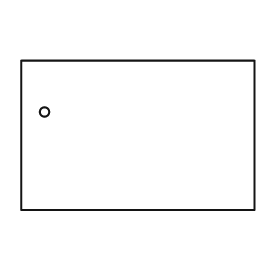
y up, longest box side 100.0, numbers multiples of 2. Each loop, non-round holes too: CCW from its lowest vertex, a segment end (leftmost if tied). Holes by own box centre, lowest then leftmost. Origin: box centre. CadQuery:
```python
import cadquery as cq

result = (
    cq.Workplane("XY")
    .moveTo(-50.0, -32.0)
    .lineTo(50.0, -32.0)
    .lineTo(50.0, 32.0)
    .lineTo(-50.0, 32.0)
    .close()
    .moveTo(-40.0, 10.0)
    .circle(2.0)
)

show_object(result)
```